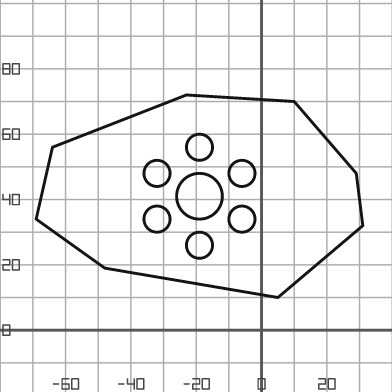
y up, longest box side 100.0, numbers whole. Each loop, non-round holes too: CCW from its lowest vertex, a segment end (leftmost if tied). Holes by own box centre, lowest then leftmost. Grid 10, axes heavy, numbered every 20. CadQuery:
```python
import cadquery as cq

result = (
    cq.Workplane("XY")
    .moveTo(5.0, 10.0)
    .lineTo(31.0, 32.0)
    .lineTo(29.0, 48.0)
    .lineTo(10.0, 70.0)
    .lineTo(-23.0, 72.0)
    .lineTo(-64.0, 56.0)
    .lineTo(-69.0, 34.0)
    .lineTo(-48.0, 19.0)
    .close()
    .moveTo(-19.0, 26.0)
    .circle(4.0)
    .moveTo(-32.0, 34.0)
    .circle(4.0)
    .moveTo(-6.0, 34.0)
    .circle(4.0)
    .moveTo(-19.0, 41.0)
    .circle(7.0)
    .moveTo(-32.0, 48.0)
    .circle(4.0)
    .moveTo(-6.0, 48.0)
    .circle(4.0)
    .moveTo(-19.0, 56.0)
    .circle(4.0)
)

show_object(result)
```